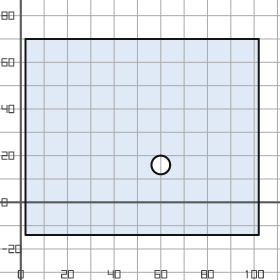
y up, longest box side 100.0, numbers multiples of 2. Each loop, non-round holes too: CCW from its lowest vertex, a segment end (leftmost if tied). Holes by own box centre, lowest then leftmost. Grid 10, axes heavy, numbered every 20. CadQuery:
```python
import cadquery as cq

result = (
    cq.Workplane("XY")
    .moveTo(2.0, -14.0)
    .lineTo(102.0, -14.0)
    .lineTo(102.0, 70.0)
    .lineTo(2.0, 70.0)
    .close()
    .moveTo(60.0, 16.0)
    .circle(4.0)
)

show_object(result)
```